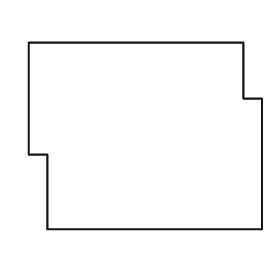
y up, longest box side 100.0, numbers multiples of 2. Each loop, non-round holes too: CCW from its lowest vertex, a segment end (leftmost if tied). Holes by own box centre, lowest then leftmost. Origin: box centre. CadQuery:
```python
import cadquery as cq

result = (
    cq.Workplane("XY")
    .moveTo(-42.0, -40.0)
    .lineTo(50.0, -40.0)
    .lineTo(50.0, 16.0)
    .lineTo(42.0, 16.0)
    .lineTo(42.0, 40.0)
    .lineTo(-50.0, 40.0)
    .lineTo(-50.0, -8.0)
    .lineTo(-42.0, -8.0)
    .close()
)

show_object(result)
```